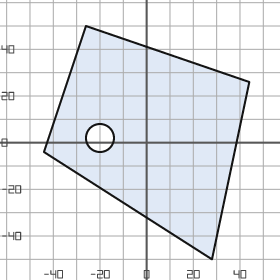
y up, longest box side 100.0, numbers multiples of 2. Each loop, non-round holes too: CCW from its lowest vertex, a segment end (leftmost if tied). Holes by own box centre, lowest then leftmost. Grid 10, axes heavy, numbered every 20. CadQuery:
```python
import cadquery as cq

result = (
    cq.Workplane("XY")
    .moveTo(28.0, -50.0)
    .lineTo(44.0, 26.0)
    .lineTo(-26.0, 50.0)
    .lineTo(-44.0, -4.0)
    .close()
    .moveTo(-20.0, 2.0)
    .circle(6.0)
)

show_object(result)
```